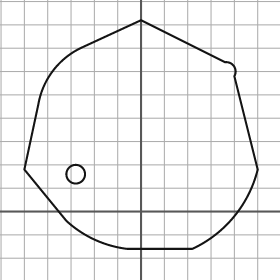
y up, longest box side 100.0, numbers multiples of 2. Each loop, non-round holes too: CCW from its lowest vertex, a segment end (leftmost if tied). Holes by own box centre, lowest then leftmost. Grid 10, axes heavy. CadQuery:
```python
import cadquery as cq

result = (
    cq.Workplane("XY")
    .moveTo(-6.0, -16.0)
    .lineTo(22.0, -16.0)
    .threePointArc((40.0, -2.0), (50.0, 18.0))
    .lineTo(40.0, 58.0)
    .threePointArc((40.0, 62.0), (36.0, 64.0))
    .lineTo(0.0, 82.0)
    .lineTo(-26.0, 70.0)
    .threePointArc((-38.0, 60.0), (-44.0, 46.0))
    .lineTo(-50.0, 18.0)
    .lineTo(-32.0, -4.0)
    .threePointArc((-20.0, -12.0), (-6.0, -16.0))
    .close()
    .moveTo(-28.0, 16.0)
    .circle(4.0)
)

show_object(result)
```